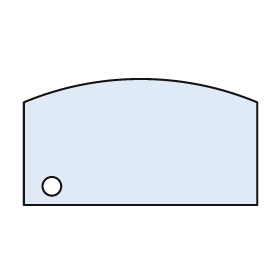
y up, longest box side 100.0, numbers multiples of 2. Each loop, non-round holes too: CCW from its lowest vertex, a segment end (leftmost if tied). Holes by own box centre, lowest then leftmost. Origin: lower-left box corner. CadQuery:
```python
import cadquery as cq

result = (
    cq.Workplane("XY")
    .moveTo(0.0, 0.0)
    .lineTo(100.0, 0.0)
    .lineTo(100.0, 44.0)
    .threePointArc((50.0, 54.0), (0.0, 44.0))
    .close()
    .moveTo(12.0, 8.0)
    .circle(4.0)
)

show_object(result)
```